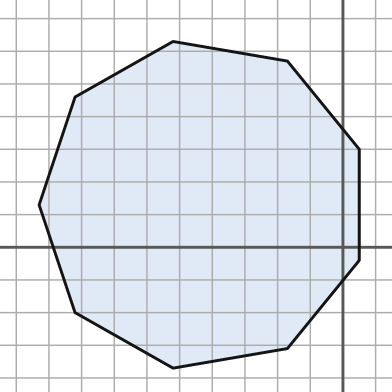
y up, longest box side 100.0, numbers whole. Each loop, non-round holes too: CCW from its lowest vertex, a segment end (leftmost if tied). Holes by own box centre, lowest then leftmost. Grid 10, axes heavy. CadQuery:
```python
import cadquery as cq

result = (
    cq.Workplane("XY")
    .moveTo(-52.0, -37.0)
    .lineTo(-17.0, -31.0)
    .lineTo(5.0, -4.0)
    .lineTo(5.0, 30.0)
    .lineTo(-17.0, 57.0)
    .lineTo(-52.0, 63.0)
    .lineTo(-82.0, 46.0)
    .lineTo(-93.0, 13.0)
    .lineTo(-82.0, -20.0)
    .close()
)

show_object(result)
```